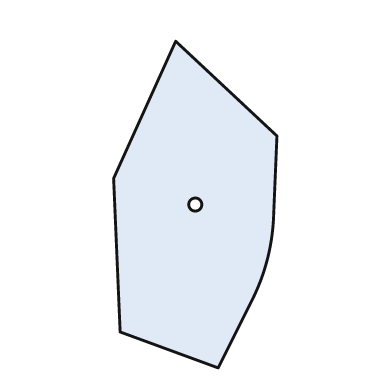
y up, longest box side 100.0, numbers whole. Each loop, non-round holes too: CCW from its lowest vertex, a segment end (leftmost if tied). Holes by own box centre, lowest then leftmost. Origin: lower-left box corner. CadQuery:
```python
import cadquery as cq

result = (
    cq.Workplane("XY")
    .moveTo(32.0, 0.0)
    .lineTo(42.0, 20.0)
    .threePointArc((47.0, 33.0), (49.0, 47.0))
    .lineTo(50.0, 71.0)
    .lineTo(19.0, 100.0)
    .lineTo(0.0, 58.0)
    .lineTo(2.0, 11.0)
    .close()
    .moveTo(25.0, 50.0)
    .circle(2.0)
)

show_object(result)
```